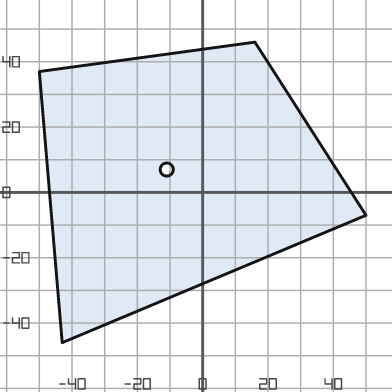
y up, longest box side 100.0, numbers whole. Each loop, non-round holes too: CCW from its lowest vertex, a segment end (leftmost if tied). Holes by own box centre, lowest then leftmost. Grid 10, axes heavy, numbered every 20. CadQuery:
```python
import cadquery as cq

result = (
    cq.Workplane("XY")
    .moveTo(-43.0, -46.0)
    .lineTo(50.0, -7.0)
    .lineTo(16.0, 46.0)
    .lineTo(-50.0, 37.0)
    .close()
    .moveTo(-11.0, 7.0)
    .circle(2.0)
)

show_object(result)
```